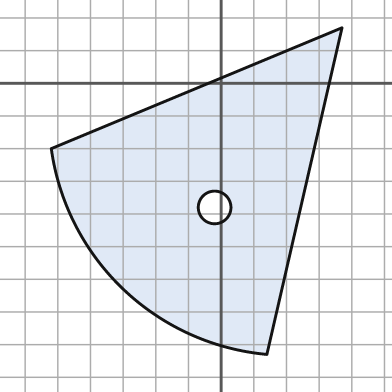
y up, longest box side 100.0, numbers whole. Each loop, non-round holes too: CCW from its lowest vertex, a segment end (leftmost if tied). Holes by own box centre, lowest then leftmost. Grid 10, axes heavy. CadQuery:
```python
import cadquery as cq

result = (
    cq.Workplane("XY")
    .moveTo(14.0, -83.0)
    .lineTo(37.0, 17.0)
    .lineTo(-52.0, -20.0)
    .threePointArc((-30.0, -63.0), (14.0, -83.0))
    .close()
    .moveTo(-2.0, -38.0)
    .circle(5.0)
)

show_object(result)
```